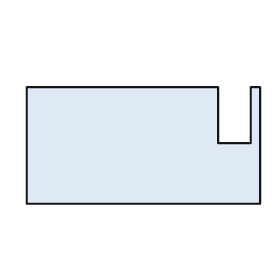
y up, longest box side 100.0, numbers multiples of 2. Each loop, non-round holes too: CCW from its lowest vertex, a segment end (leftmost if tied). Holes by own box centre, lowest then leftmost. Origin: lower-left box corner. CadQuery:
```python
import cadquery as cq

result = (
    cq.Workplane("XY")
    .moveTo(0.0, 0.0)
    .lineTo(100.0, 0.0)
    .lineTo(100.0, 50.0)
    .lineTo(96.0, 50.0)
    .lineTo(96.0, 26.0)
    .lineTo(82.0, 26.0)
    .lineTo(82.0, 50.0)
    .lineTo(0.0, 50.0)
    .close()
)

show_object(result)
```